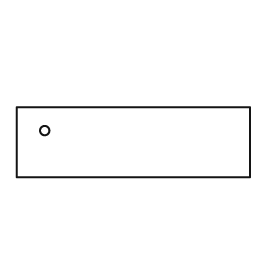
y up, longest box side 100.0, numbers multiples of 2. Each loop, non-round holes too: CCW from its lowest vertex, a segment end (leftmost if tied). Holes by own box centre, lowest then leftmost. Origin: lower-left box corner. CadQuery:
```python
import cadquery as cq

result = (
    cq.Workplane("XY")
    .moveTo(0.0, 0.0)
    .lineTo(100.0, 0.0)
    .lineTo(100.0, 30.0)
    .lineTo(0.0, 30.0)
    .close()
    .moveTo(12.0, 20.0)
    .circle(2.0)
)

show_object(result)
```